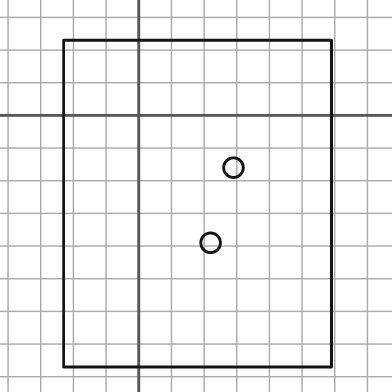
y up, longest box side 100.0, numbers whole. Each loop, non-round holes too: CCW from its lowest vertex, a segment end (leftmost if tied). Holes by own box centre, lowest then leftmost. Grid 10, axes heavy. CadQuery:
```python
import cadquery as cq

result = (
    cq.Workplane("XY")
    .moveTo(-23.0, -77.0)
    .lineTo(59.0, -77.0)
    .lineTo(59.0, 23.0)
    .lineTo(-23.0, 23.0)
    .close()
    .moveTo(22.0, -39.0)
    .circle(3.0)
    .moveTo(29.0, -16.0)
    .circle(3.0)
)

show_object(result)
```